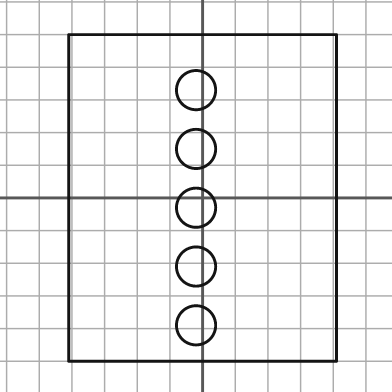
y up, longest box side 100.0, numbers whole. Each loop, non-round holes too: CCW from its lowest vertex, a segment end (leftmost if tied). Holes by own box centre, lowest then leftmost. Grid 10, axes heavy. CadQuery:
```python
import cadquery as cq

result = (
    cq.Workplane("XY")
    .moveTo(-41.0, -50.0)
    .lineTo(41.0, -50.0)
    .lineTo(41.0, 50.0)
    .lineTo(-41.0, 50.0)
    .close()
    .moveTo(-2.0, -39.0)
    .circle(6.0)
    .moveTo(-2.0, -21.0)
    .circle(6.0)
    .moveTo(-2.0, -3.0)
    .circle(6.0)
    .moveTo(-2.0, 15.0)
    .circle(6.0)
    .moveTo(-2.0, 33.0)
    .circle(6.0)
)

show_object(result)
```